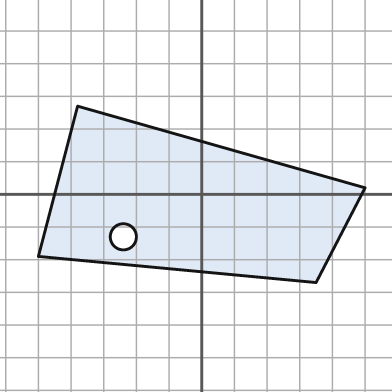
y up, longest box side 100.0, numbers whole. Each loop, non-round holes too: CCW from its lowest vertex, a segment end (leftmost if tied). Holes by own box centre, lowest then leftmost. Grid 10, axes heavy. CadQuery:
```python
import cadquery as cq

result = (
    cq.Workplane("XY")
    .moveTo(35.0, -27.0)
    .lineTo(50.0, 2.0)
    .lineTo(-38.0, 27.0)
    .lineTo(-50.0, -19.0)
    .close()
    .moveTo(-24.0, -13.0)
    .circle(4.0)
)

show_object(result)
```